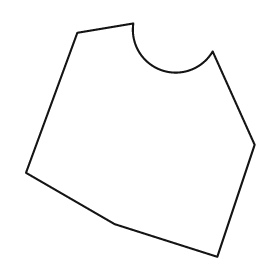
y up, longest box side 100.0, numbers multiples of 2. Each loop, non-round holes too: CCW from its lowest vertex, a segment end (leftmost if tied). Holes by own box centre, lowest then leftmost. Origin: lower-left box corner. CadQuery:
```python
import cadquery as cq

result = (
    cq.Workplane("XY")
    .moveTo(82.0, 0.0)
    .lineTo(98.0, 48.0)
    .lineTo(80.0, 88.0)
    .threePointArc((58.0, 80.0), (46.0, 100.0))
    .lineTo(22.0, 96.0)
    .lineTo(0.0, 36.0)
    .lineTo(38.0, 14.0)
    .close()
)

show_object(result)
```